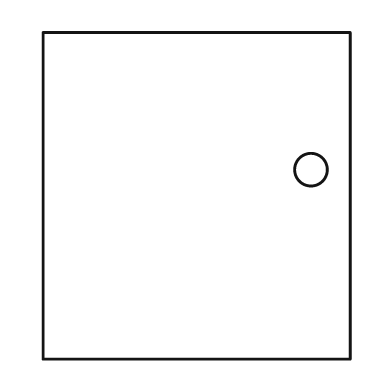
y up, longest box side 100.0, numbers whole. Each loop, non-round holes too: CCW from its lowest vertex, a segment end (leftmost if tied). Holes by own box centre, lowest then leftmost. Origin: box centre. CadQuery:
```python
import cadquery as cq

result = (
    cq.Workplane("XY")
    .moveTo(-47.0, -50.0)
    .lineTo(47.0, -50.0)
    .lineTo(47.0, 50.0)
    .lineTo(-47.0, 50.0)
    .close()
    .moveTo(35.0, 8.0)
    .circle(5.0)
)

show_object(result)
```